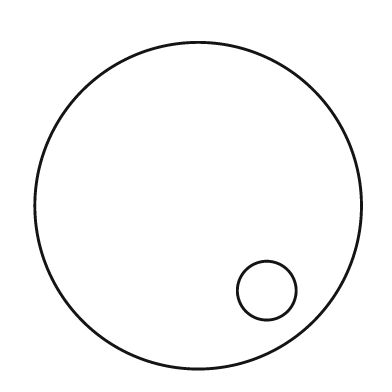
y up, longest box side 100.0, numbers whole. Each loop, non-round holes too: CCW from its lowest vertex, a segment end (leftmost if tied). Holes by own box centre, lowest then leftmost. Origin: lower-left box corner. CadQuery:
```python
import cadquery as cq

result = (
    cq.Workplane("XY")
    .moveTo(50.0, 50.0)
    .circle(50.0)
    .moveTo(71.0, 24.0)
    .circle(9.0)
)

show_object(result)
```